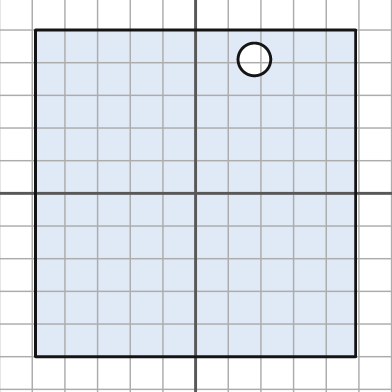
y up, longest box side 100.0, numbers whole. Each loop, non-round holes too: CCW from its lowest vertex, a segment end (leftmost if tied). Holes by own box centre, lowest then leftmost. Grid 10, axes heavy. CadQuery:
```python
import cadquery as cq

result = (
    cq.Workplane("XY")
    .moveTo(-49.0, -50.0)
    .lineTo(49.0, -50.0)
    .lineTo(49.0, 50.0)
    .lineTo(-49.0, 50.0)
    .close()
    .moveTo(18.0, 41.0)
    .circle(5.0)
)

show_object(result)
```